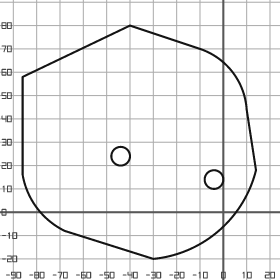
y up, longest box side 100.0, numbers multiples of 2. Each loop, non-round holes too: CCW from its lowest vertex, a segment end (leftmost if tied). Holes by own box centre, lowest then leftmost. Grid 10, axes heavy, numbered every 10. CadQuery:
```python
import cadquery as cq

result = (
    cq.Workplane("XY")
    .moveTo(-30.0, -20.0)
    .threePointArc((-2.0, -8.0), (14.0, 18.0))
    .lineTo(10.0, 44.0)
    .threePointArc((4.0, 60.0), (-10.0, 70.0))
    .lineTo(-40.0, 80.0)
    .lineTo(-86.0, 58.0)
    .lineTo(-86.0, 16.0)
    .threePointArc((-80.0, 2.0), (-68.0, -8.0))
    .close()
    .moveTo(-4.0, 14.0)
    .circle(4.0)
    .moveTo(-44.0, 24.0)
    .circle(4.0)
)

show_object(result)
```